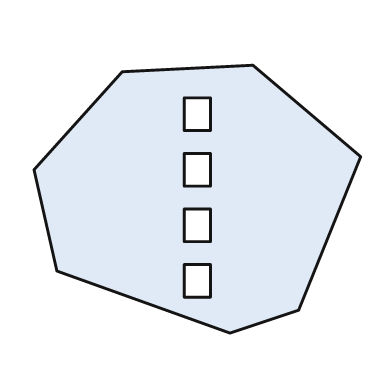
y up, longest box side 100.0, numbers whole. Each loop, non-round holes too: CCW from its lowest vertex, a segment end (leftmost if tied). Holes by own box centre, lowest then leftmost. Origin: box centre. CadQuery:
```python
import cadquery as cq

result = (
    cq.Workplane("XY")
    .moveTo(10.0, -41.0)
    .lineTo(31.0, -34.0)
    .lineTo(50.0, 13.0)
    .lineTo(17.0, 41.0)
    .lineTo(-23.0, 39.0)
    .lineTo(-50.0, 9.0)
    .lineTo(-43.0, -22.0)
    .close()
    .moveTo(-4.0, -30.0)
    .lineTo(4.0, -30.0)
    .lineTo(4.0, -20.0)
    .lineTo(-4.0, -20.0)
    .close()
    .moveTo(-4.0, -13.0)
    .lineTo(4.0, -13.0)
    .lineTo(4.0, -3.0)
    .lineTo(-4.0, -3.0)
    .close()
    .moveTo(-4.0, 4.0)
    .lineTo(4.0, 4.0)
    .lineTo(4.0, 14.0)
    .lineTo(-4.0, 14.0)
    .close()
    .moveTo(-4.0, 21.0)
    .lineTo(4.0, 21.0)
    .lineTo(4.0, 31.0)
    .lineTo(-4.0, 31.0)
    .close()
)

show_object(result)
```